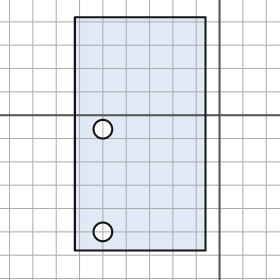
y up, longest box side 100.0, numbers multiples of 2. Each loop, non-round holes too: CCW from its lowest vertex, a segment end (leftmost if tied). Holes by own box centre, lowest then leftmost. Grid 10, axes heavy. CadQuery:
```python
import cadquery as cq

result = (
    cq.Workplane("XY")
    .moveTo(-62.0, -58.0)
    .lineTo(-6.0, -58.0)
    .lineTo(-6.0, 42.0)
    .lineTo(-62.0, 42.0)
    .close()
    .moveTo(-50.0, -50.0)
    .circle(4.0)
    .moveTo(-50.0, -6.0)
    .circle(4.0)
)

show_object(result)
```